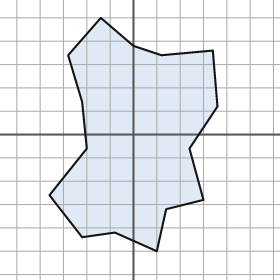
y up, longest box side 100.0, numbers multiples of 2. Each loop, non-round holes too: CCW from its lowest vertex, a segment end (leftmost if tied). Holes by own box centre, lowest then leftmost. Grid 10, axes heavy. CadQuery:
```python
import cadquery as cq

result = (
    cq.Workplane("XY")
    .moveTo(10.0, -50.0)
    .lineTo(14.0, -32.0)
    .lineTo(30.0, -28.0)
    .lineTo(24.0, -6.0)
    .lineTo(36.0, 12.0)
    .lineTo(34.0, 36.0)
    .lineTo(12.0, 34.0)
    .lineTo(0.0, 38.0)
    .lineTo(-14.0, 50.0)
    .lineTo(-28.0, 34.0)
    .lineTo(-22.0, 14.0)
    .lineTo(-20.0, -6.0)
    .lineTo(-36.0, -26.0)
    .lineTo(-22.0, -44.0)
    .lineTo(-8.0, -42.0)
    .close()
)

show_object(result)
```